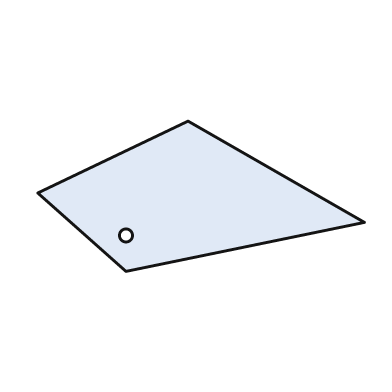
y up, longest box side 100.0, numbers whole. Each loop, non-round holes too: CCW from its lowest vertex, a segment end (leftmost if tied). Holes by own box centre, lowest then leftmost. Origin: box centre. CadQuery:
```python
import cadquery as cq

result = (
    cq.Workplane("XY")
    .moveTo(-23.0, -23.0)
    .lineTo(50.0, -8.0)
    .lineTo(-4.0, 23.0)
    .lineTo(-50.0, 1.0)
    .close()
    .moveTo(-23.0, -12.0)
    .circle(2.0)
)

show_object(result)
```